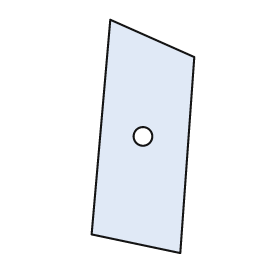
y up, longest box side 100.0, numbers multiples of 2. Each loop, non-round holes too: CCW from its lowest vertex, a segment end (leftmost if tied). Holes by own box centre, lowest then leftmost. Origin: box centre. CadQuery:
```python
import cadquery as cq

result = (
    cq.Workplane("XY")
    .moveTo(16.0, -50.0)
    .lineTo(22.0, 34.0)
    .lineTo(-14.0, 50.0)
    .lineTo(-22.0, -42.0)
    .close()
    .moveTo(0.0, 0.0)
    .circle(4.0)
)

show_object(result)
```